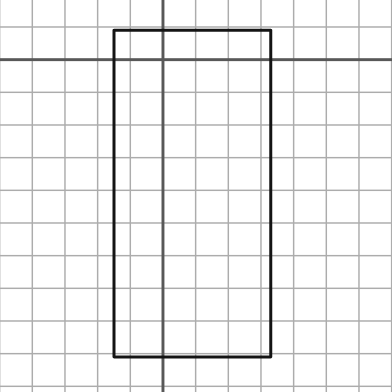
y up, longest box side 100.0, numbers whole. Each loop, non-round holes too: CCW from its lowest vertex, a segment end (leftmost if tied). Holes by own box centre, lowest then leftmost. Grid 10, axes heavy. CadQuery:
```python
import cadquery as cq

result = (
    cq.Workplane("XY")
    .moveTo(-15.0, -91.0)
    .lineTo(33.0, -91.0)
    .lineTo(33.0, 9.0)
    .lineTo(-15.0, 9.0)
    .close()
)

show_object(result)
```